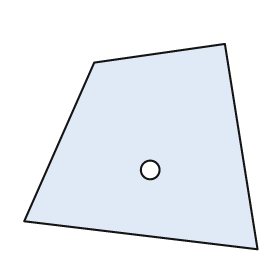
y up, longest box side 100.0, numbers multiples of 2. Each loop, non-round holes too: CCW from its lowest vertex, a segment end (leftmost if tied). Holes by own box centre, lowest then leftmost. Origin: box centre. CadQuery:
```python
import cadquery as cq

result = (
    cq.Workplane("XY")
    .moveTo(50.0, -44.0)
    .lineTo(36.0, 44.0)
    .lineTo(-20.0, 36.0)
    .lineTo(-50.0, -32.0)
    .close()
    .moveTo(4.0, -10.0)
    .circle(4.0)
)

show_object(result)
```